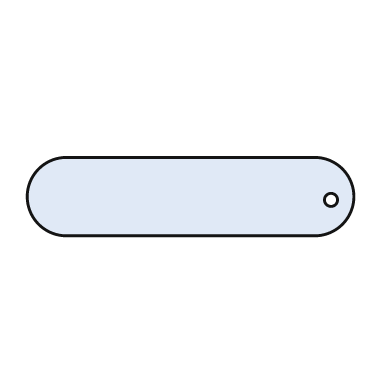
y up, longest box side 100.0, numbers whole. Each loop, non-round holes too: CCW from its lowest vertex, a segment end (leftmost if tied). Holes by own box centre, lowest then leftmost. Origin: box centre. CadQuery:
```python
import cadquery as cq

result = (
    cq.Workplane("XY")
    .moveTo(-38.0, -12.0)
    .lineTo(38.0, -12.0)
    .threePointArc((50.0, 0.0), (38.0, 12.0))
    .lineTo(-38.0, 12.0)
    .threePointArc((-50.0, 0.0), (-38.0, -12.0))
    .close()
    .moveTo(43.0, -1.0)
    .circle(2.0)
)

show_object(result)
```